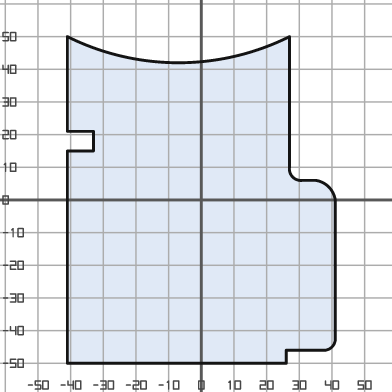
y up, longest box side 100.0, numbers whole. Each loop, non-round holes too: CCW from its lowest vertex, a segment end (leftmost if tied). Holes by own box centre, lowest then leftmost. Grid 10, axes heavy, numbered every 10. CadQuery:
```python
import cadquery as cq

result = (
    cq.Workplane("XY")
    .moveTo(-41.0, -50.0)
    .lineTo(26.0, -50.0)
    .lineTo(26.0, -46.0)
    .lineTo(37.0, -46.0)
    .threePointArc((40.0, -45.0), (41.0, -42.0))
    .lineTo(41.0, 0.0)
    .threePointArc((39.0, 4.0), (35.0, 6.0))
    .lineTo(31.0, 6.0)
    .threePointArc((28.0, 7.0), (27.0, 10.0))
    .lineTo(27.0, 50.0)
    .threePointArc((-7.0, 42.0), (-41.0, 50.0))
    .lineTo(-41.0, 21.0)
    .lineTo(-33.0, 21.0)
    .lineTo(-33.0, 15.0)
    .lineTo(-41.0, 15.0)
    .close()
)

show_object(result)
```